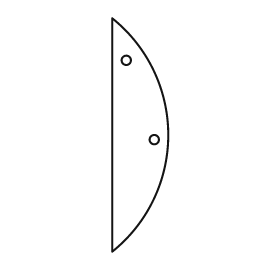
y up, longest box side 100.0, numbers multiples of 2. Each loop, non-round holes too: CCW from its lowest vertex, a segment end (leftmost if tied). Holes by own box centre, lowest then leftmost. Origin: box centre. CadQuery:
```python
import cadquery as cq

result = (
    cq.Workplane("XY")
    .moveTo(-12.0, -50.0)
    .threePointArc((12.0, 0.0), (-12.0, 50.0))
    .close()
    .moveTo(6.0, -2.0)
    .circle(2.0)
    .moveTo(-6.0, 32.0)
    .circle(2.0)
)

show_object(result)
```